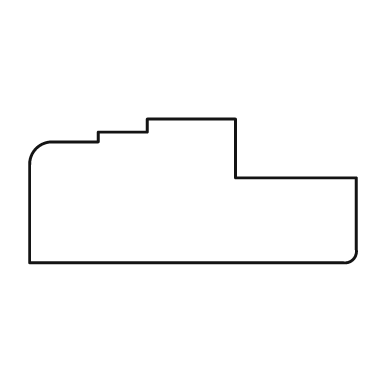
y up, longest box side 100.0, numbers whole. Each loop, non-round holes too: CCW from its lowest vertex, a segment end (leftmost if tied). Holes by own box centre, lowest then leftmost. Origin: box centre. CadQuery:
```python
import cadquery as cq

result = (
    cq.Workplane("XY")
    .moveTo(-50.0, -22.0)
    .lineTo(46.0, -22.0)
    .threePointArc((49.0, -21.0), (50.0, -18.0))
    .lineTo(50.0, 4.0)
    .lineTo(13.0, 4.0)
    .lineTo(13.0, 22.0)
    .lineTo(-14.0, 22.0)
    .lineTo(-14.0, 18.0)
    .lineTo(-29.0, 18.0)
    .lineTo(-29.0, 15.0)
    .lineTo(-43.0, 15.0)
    .threePointArc((-48.0, 13.0), (-50.0, 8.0))
    .close()
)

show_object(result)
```